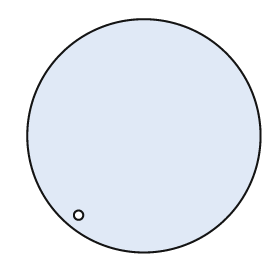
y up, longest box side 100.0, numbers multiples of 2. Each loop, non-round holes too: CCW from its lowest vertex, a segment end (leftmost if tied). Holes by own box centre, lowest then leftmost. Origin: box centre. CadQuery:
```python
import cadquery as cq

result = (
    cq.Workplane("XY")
    .moveTo(0.0, 0.0)
    .circle(50.0)
    .moveTo(-28.0, -34.0)
    .circle(2.0)
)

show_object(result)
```